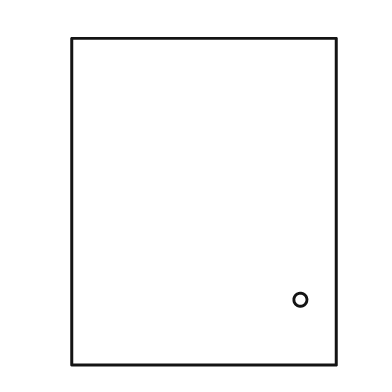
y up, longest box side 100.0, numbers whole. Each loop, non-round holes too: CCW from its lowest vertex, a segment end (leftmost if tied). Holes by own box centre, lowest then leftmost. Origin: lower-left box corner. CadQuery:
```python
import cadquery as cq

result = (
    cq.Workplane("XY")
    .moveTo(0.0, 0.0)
    .lineTo(81.0, 0.0)
    .lineTo(81.0, 100.0)
    .lineTo(0.0, 100.0)
    .close()
    .moveTo(70.0, 20.0)
    .circle(2.0)
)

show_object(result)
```